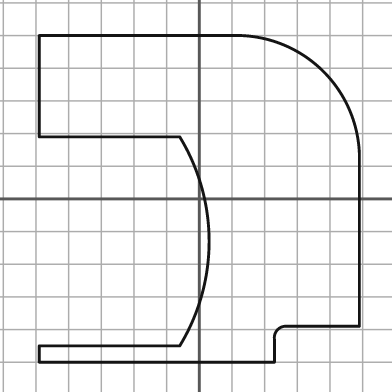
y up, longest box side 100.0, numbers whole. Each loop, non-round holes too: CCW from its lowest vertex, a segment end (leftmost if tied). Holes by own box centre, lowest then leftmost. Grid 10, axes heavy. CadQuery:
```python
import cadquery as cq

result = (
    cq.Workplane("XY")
    .moveTo(-49.0, -50.0)
    .lineTo(23.0, -50.0)
    .lineTo(23.0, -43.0)
    .threePointArc((24.0, -40.0), (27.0, -39.0))
    .lineTo(49.0, -39.0)
    .lineTo(49.0, 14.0)
    .threePointArc((38.0, 39.0), (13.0, 50.0))
    .lineTo(-49.0, 50.0)
    .lineTo(-49.0, 19.0)
    .lineTo(-6.0, 19.0)
    .threePointArc((3.0, -13.0), (-6.0, -45.0))
    .lineTo(-49.0, -45.0)
    .close()
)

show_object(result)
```